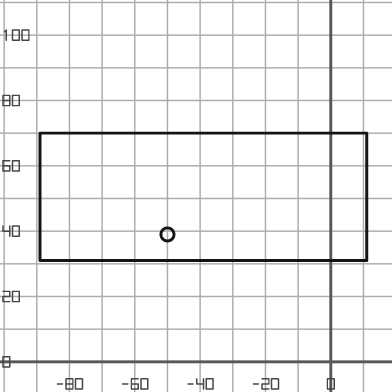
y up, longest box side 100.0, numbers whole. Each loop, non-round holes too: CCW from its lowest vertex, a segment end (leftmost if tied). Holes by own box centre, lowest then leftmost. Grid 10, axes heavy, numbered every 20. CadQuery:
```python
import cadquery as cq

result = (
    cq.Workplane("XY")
    .moveTo(-89.0, 31.0)
    .lineTo(11.0, 31.0)
    .lineTo(11.0, 70.0)
    .lineTo(-89.0, 70.0)
    .close()
    .moveTo(-50.0, 39.0)
    .circle(2.0)
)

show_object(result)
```